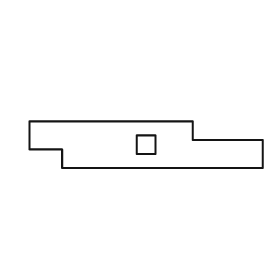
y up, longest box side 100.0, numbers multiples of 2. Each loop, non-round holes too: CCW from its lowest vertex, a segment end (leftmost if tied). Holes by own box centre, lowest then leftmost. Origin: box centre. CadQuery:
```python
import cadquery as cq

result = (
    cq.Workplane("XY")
    .moveTo(-36.0, -10.0)
    .lineTo(50.0, -10.0)
    .lineTo(50.0, 2.0)
    .lineTo(20.0, 2.0)
    .lineTo(20.0, 10.0)
    .lineTo(-50.0, 10.0)
    .lineTo(-50.0, -2.0)
    .lineTo(-36.0, -2.0)
    .close()
    .moveTo(-4.0, -4.0)
    .lineTo(4.0, -4.0)
    .lineTo(4.0, 4.0)
    .lineTo(-4.0, 4.0)
    .close()
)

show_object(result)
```